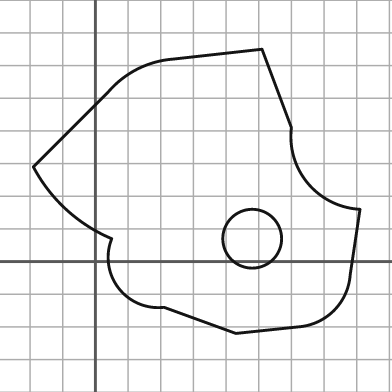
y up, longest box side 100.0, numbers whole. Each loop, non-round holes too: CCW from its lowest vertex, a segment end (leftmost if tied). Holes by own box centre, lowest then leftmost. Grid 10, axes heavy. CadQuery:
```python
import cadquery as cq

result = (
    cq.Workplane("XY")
    .moveTo(43.0, -22.0)
    .lineTo(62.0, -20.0)
    .threePointArc((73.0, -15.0), (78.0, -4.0))
    .lineTo(81.0, 16.0)
    .threePointArc((65.0, 24.0), (60.0, 41.0))
    .lineTo(51.0, 65.0)
    .lineTo(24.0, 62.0)
    .threePointArc((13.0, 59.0), (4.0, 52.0))
    .lineTo(-19.0, 29.0)
    .threePointArc((-9.0, 16.0), (5.0, 7.0))
    .threePointArc((7.0, -8.0), (21.0, -14.0))
    .close()
    .moveTo(48.0, 7.0)
    .circle(9.0)
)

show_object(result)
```